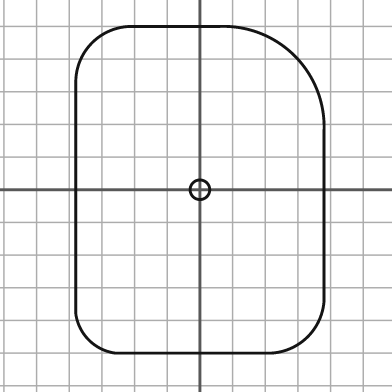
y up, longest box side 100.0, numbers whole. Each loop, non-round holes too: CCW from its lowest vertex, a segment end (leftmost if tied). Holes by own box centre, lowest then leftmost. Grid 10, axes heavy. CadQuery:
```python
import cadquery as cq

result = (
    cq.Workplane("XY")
    .moveTo(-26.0, -50.0)
    .lineTo(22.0, -50.0)
    .threePointArc((33.0, -45.0), (38.0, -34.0))
    .lineTo(38.0, 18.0)
    .threePointArc((29.0, 41.0), (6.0, 50.0))
    .lineTo(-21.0, 50.0)
    .threePointArc((-33.0, 45.0), (-38.0, 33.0))
    .lineTo(-38.0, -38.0)
    .threePointArc((-34.0, -46.0), (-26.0, -50.0))
    .close()
    .moveTo(0.0, 0.0)
    .circle(3.0)
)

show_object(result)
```